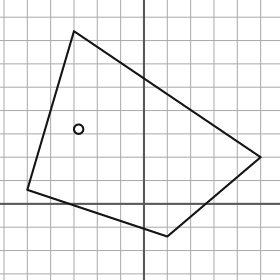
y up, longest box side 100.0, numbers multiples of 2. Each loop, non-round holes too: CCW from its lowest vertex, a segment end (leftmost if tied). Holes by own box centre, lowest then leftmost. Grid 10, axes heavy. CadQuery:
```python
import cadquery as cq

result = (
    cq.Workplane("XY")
    .moveTo(10.0, -14.0)
    .lineTo(50.0, 20.0)
    .lineTo(-30.0, 74.0)
    .lineTo(-50.0, 6.0)
    .close()
    .moveTo(-28.0, 32.0)
    .circle(2.0)
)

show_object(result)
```